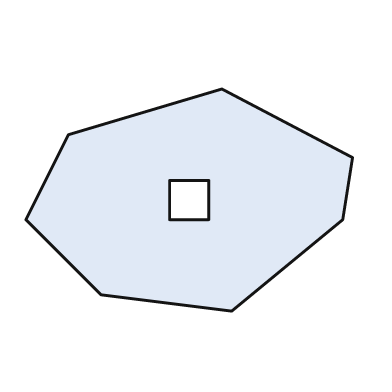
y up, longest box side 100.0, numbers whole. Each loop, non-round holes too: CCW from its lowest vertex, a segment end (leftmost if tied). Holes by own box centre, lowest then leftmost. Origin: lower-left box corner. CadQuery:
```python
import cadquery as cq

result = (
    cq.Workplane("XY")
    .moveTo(63.0, 0.0)
    .lineTo(97.0, 28.0)
    .lineTo(100.0, 47.0)
    .lineTo(60.0, 68.0)
    .lineTo(13.0, 54.0)
    .lineTo(0.0, 28.0)
    .lineTo(23.0, 5.0)
    .close()
    .moveTo(44.0, 28.0)
    .lineTo(56.0, 28.0)
    .lineTo(56.0, 40.0)
    .lineTo(44.0, 40.0)
    .close()
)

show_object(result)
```